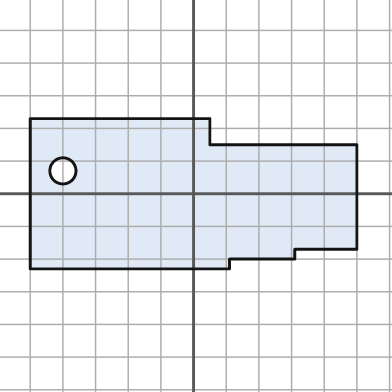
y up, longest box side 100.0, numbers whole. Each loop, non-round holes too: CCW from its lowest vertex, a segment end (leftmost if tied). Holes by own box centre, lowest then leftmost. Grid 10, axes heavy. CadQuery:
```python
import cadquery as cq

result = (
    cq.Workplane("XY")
    .moveTo(-50.0, -23.0)
    .lineTo(11.0, -23.0)
    .lineTo(11.0, -20.0)
    .lineTo(31.0, -20.0)
    .lineTo(31.0, -17.0)
    .lineTo(50.0, -17.0)
    .lineTo(50.0, 15.0)
    .lineTo(5.0, 15.0)
    .lineTo(5.0, 23.0)
    .lineTo(-50.0, 23.0)
    .close()
    .moveTo(-40.0, 7.0)
    .circle(4.0)
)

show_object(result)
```